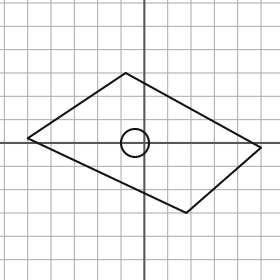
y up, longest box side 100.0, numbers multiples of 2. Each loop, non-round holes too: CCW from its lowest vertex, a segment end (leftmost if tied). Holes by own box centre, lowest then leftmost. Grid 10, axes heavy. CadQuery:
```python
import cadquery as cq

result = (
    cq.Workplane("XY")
    .moveTo(18.0, -30.0)
    .lineTo(50.0, -2.0)
    .lineTo(-8.0, 30.0)
    .lineTo(-50.0, 2.0)
    .close()
    .moveTo(-4.0, 0.0)
    .circle(6.0)
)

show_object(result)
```